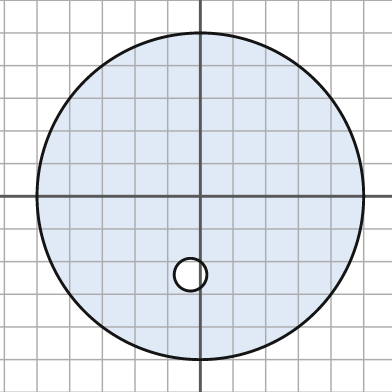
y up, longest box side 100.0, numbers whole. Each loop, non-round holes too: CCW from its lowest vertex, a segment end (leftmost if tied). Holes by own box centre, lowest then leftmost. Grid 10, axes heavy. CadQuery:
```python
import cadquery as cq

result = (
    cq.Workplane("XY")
    .moveTo(0.0, 0.0)
    .circle(50.0)
    .moveTo(-3.0, -24.0)
    .circle(5.0)
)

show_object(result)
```